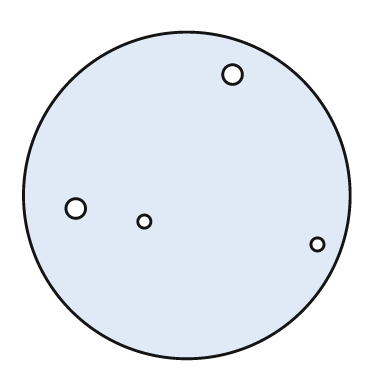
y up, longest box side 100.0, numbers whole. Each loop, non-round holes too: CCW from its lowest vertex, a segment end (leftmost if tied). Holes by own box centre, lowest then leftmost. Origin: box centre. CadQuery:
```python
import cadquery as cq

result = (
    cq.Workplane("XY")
    .moveTo(0.0, 0.0)
    .circle(50.0)
    .moveTo(40.0, -15.0)
    .circle(2.0)
    .moveTo(-13.0, -8.0)
    .circle(2.0)
    .moveTo(-34.0, -4.0)
    .circle(3.0)
    .moveTo(14.0, 37.0)
    .circle(3.0)
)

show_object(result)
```